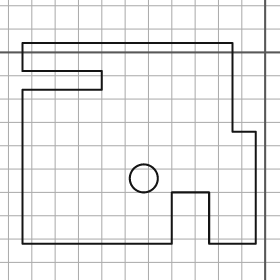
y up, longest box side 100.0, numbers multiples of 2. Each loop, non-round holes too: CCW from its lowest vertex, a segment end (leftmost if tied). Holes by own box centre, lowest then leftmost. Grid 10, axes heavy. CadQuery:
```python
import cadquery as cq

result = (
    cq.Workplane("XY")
    .moveTo(-104.0, -82.0)
    .lineTo(-40.0, -82.0)
    .lineTo(-40.0, -60.0)
    .lineTo(-24.0, -60.0)
    .lineTo(-24.0, -82.0)
    .lineTo(-4.0, -82.0)
    .lineTo(-4.0, -34.0)
    .lineTo(-14.0, -34.0)
    .lineTo(-14.0, 4.0)
    .lineTo(-104.0, 4.0)
    .lineTo(-104.0, -8.0)
    .lineTo(-70.0, -8.0)
    .lineTo(-70.0, -16.0)
    .lineTo(-104.0, -16.0)
    .close()
    .moveTo(-52.0, -54.0)
    .circle(6.0)
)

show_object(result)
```